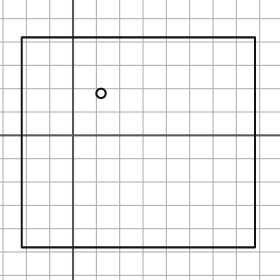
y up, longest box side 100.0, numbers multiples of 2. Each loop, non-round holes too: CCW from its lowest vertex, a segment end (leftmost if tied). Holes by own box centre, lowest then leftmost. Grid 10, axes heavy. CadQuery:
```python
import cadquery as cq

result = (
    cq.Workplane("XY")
    .moveTo(-22.0, -48.0)
    .lineTo(78.0, -48.0)
    .lineTo(78.0, 42.0)
    .lineTo(-22.0, 42.0)
    .close()
    .moveTo(12.0, 18.0)
    .circle(2.0)
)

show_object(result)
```